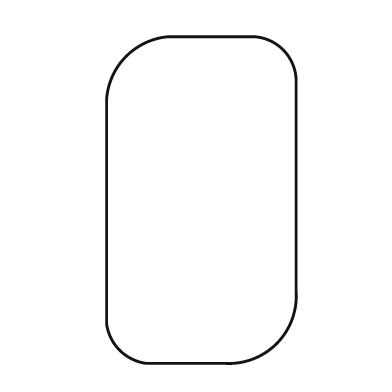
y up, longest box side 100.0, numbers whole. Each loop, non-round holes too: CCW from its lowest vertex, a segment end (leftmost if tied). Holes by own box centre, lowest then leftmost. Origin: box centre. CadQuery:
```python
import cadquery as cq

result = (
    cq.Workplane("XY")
    .moveTo(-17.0, -50.0)
    .lineTo(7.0, -50.0)
    .threePointArc((23.0, -44.0), (29.0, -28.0))
    .lineTo(29.0, 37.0)
    .threePointArc((25.0, 46.0), (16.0, 50.0))
    .lineTo(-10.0, 50.0)
    .threePointArc((-23.0, 44.0), (-29.0, 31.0))
    .lineTo(-29.0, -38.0)
    .threePointArc((-25.0, -46.0), (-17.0, -50.0))
    .close()
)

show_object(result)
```